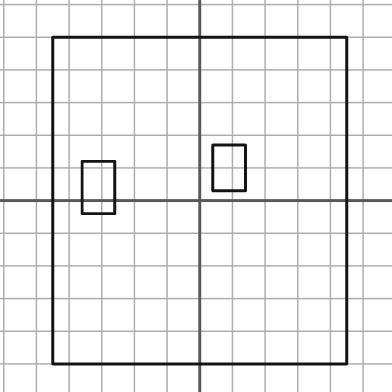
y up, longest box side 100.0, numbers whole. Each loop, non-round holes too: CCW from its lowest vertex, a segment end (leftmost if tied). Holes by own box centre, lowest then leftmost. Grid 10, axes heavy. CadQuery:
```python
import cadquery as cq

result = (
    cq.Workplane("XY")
    .moveTo(-45.0, -50.0)
    .lineTo(45.0, -50.0)
    .lineTo(45.0, 50.0)
    .lineTo(-45.0, 50.0)
    .close()
    .moveTo(-36.0, -4.0)
    .lineTo(-26.0, -4.0)
    .lineTo(-26.0, 12.0)
    .lineTo(-36.0, 12.0)
    .close()
    .moveTo(4.0, 3.0)
    .lineTo(14.0, 3.0)
    .lineTo(14.0, 17.0)
    .lineTo(4.0, 17.0)
    .close()
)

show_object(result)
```